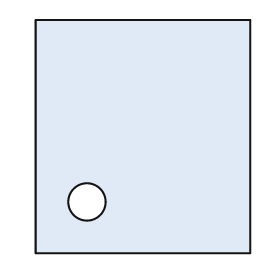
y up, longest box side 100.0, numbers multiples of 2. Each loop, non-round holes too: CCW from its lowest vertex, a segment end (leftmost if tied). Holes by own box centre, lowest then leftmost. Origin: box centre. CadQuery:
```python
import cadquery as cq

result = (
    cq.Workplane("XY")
    .moveTo(-46.0, -50.0)
    .lineTo(46.0, -50.0)
    .lineTo(46.0, 50.0)
    .lineTo(-46.0, 50.0)
    .close()
    .moveTo(-24.0, -28.0)
    .circle(8.0)
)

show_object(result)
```